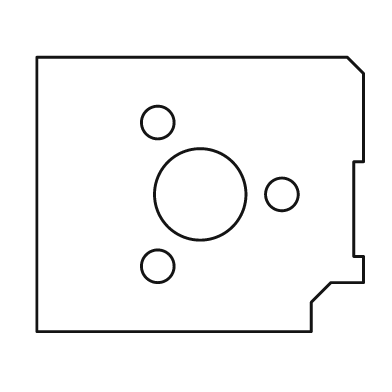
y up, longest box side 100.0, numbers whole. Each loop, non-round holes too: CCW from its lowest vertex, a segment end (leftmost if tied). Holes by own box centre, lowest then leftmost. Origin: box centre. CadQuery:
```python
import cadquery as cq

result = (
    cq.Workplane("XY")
    .moveTo(-50.0, -42.0)
    .lineTo(34.0, -42.0)
    .lineTo(34.0, -33.0)
    .lineTo(40.0, -27.0)
    .lineTo(50.0, -27.0)
    .lineTo(50.0, -19.0)
    .lineTo(47.0, -19.0)
    .lineTo(47.0, 10.0)
    .lineTo(50.0, 10.0)
    .lineTo(50.0, 37.0)
    .lineTo(45.0, 42.0)
    .lineTo(-50.0, 42.0)
    .close()
    .moveTo(-13.0, -22.0)
    .circle(5.0)
    .moveTo(0.0, 0.0)
    .circle(14.0)
    .moveTo(25.0, 0.0)
    .circle(5.0)
    .moveTo(-13.0, 22.0)
    .circle(5.0)
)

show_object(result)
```